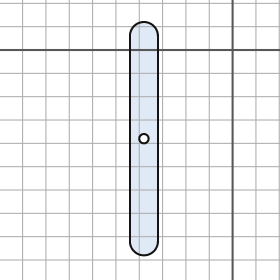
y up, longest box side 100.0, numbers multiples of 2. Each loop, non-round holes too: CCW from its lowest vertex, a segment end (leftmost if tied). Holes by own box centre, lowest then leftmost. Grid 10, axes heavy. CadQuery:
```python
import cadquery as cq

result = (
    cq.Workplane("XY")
    .moveTo(-44.0, -82.0)
    .threePointArc((-38.0, -88.0), (-32.0, -82.0))
    .lineTo(-32.0, 6.0)
    .threePointArc((-38.0, 12.0), (-44.0, 6.0))
    .close()
    .moveTo(-38.0, -38.0)
    .circle(2.0)
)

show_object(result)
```